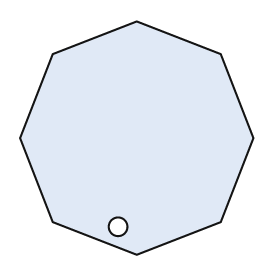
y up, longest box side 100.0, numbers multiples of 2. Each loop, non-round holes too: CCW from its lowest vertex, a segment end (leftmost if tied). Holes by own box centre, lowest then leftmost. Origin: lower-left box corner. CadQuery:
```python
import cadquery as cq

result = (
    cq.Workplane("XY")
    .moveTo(50.0, 0.0)
    .lineTo(86.0, 14.0)
    .lineTo(100.0, 50.0)
    .lineTo(86.0, 86.0)
    .lineTo(50.0, 100.0)
    .lineTo(14.0, 86.0)
    .lineTo(0.0, 50.0)
    .lineTo(14.0, 14.0)
    .close()
    .moveTo(42.0, 12.0)
    .circle(4.0)
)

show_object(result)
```